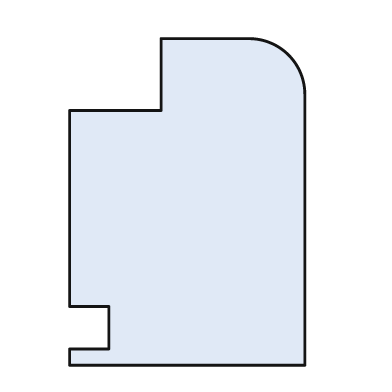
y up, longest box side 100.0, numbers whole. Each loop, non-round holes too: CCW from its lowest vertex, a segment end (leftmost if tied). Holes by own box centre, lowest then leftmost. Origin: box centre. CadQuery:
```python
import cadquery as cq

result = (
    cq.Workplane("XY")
    .moveTo(-36.0, -50.0)
    .lineTo(36.0, -50.0)
    .lineTo(36.0, 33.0)
    .threePointArc((31.0, 45.0), (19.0, 50.0))
    .lineTo(-8.0, 50.0)
    .lineTo(-8.0, 28.0)
    .lineTo(-36.0, 28.0)
    .lineTo(-36.0, -32.0)
    .lineTo(-24.0, -32.0)
    .lineTo(-24.0, -45.0)
    .lineTo(-36.0, -45.0)
    .close()
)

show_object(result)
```